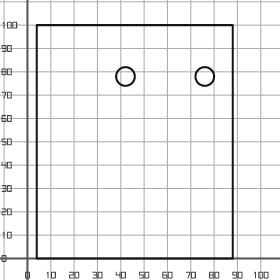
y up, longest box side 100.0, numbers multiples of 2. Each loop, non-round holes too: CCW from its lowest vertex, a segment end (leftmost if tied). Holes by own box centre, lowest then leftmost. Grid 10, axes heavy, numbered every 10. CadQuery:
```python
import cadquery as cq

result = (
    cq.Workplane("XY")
    .moveTo(4.0, 0.0)
    .lineTo(88.0, 0.0)
    .lineTo(88.0, 100.0)
    .lineTo(4.0, 100.0)
    .close()
    .moveTo(42.0, 78.0)
    .circle(4.0)
    .moveTo(76.0, 78.0)
    .circle(4.0)
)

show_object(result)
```